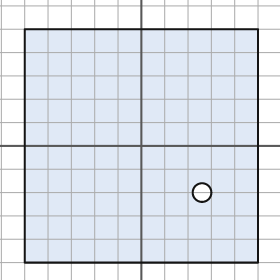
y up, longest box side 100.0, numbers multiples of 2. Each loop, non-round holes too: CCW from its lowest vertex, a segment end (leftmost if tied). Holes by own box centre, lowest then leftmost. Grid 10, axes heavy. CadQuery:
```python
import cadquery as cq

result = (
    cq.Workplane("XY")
    .moveTo(-50.0, -50.0)
    .lineTo(50.0, -50.0)
    .lineTo(50.0, 50.0)
    .lineTo(-50.0, 50.0)
    .close()
    .moveTo(26.0, -20.0)
    .circle(4.0)
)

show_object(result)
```